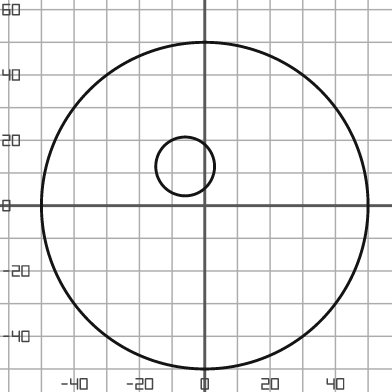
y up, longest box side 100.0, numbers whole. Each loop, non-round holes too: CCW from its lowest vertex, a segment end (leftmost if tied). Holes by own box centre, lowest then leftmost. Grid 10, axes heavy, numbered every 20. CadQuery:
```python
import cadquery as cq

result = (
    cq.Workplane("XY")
    .moveTo(0.0, 0.0)
    .circle(50.0)
    .moveTo(-6.0, 12.0)
    .circle(9.0)
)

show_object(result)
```